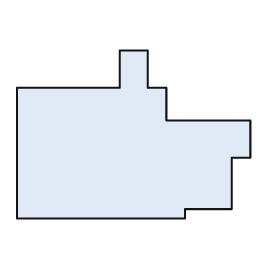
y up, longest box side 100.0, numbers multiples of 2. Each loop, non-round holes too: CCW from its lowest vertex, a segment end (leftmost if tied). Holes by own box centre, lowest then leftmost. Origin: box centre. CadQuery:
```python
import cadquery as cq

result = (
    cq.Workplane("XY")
    .moveTo(-50.0, -36.0)
    .lineTo(22.0, -36.0)
    .lineTo(22.0, -32.0)
    .lineTo(42.0, -32.0)
    .lineTo(42.0, -10.0)
    .lineTo(50.0, -10.0)
    .lineTo(50.0, 6.0)
    .lineTo(14.0, 6.0)
    .lineTo(14.0, 20.0)
    .lineTo(6.0, 20.0)
    .lineTo(6.0, 36.0)
    .lineTo(-6.0, 36.0)
    .lineTo(-6.0, 20.0)
    .lineTo(-50.0, 20.0)
    .close()
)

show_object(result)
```